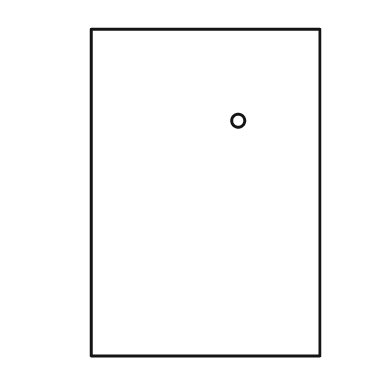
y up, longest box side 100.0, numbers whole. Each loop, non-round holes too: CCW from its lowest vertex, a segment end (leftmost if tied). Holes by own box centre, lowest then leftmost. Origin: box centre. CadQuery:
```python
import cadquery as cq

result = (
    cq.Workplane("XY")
    .moveTo(-35.0, -50.0)
    .lineTo(35.0, -50.0)
    .lineTo(35.0, 50.0)
    .lineTo(-35.0, 50.0)
    .close()
    .moveTo(10.0, 22.0)
    .circle(2.0)
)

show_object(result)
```